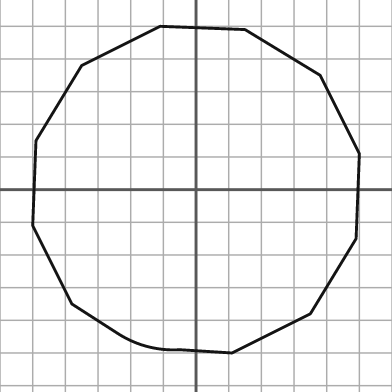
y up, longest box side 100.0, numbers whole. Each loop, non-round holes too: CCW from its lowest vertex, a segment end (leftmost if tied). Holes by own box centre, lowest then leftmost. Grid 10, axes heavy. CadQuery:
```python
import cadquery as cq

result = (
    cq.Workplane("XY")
    .moveTo(11.0, -50.0)
    .lineTo(35.0, -38.0)
    .lineTo(49.0, -15.0)
    .lineTo(50.0, 11.0)
    .lineTo(38.0, 35.0)
    .lineTo(15.0, 49.0)
    .lineTo(-11.0, 50.0)
    .lineTo(-35.0, 38.0)
    .lineTo(-49.0, 15.0)
    .lineTo(-50.0, -11.0)
    .lineTo(-38.0, -35.0)
    .lineTo(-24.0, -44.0)
    .threePointArc((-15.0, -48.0), (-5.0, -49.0))
    .close()
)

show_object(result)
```